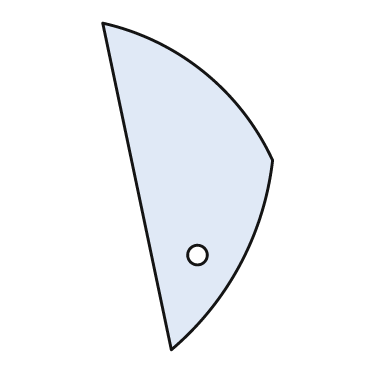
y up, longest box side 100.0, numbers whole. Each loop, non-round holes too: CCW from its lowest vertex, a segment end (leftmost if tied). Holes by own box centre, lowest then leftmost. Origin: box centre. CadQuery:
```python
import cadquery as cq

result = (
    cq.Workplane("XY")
    .moveTo(-5.0, -50.0)
    .threePointArc((16.0, -24.0), (26.0, 8.0))
    .threePointArc((5.0, 35.0), (-26.0, 50.0))
    .close()
    .moveTo(3.0, -21.0)
    .circle(3.0)
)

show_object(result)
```